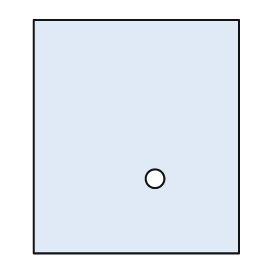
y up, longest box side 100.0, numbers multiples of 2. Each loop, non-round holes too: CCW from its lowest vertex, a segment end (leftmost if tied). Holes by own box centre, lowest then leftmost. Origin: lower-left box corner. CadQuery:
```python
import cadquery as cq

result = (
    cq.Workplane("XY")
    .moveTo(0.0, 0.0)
    .lineTo(88.0, 0.0)
    .lineTo(88.0, 100.0)
    .lineTo(0.0, 100.0)
    .close()
    .moveTo(52.0, 32.0)
    .circle(4.0)
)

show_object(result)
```